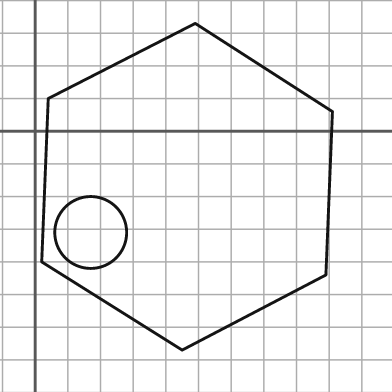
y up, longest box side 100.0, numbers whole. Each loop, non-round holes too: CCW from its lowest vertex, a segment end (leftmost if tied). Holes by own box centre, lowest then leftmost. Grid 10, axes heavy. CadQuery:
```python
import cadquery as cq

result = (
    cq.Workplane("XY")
    .moveTo(45.0, -67.0)
    .lineTo(89.0, -44.0)
    .lineTo(91.0, 6.0)
    .lineTo(49.0, 33.0)
    .lineTo(4.0, 10.0)
    .lineTo(2.0, -40.0)
    .close()
    .moveTo(17.0, -31.0)
    .circle(11.0)
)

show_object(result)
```